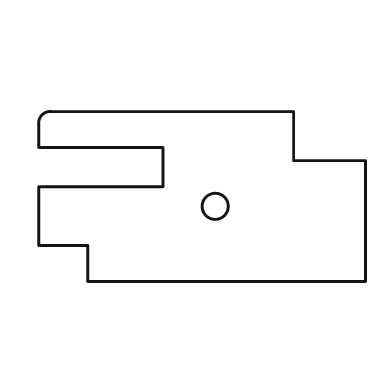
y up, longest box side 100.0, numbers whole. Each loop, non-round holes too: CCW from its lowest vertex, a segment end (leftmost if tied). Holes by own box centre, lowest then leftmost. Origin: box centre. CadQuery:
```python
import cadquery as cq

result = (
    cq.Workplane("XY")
    .moveTo(-35.0, -26.0)
    .lineTo(50.0, -26.0)
    .lineTo(50.0, 11.0)
    .lineTo(28.0, 11.0)
    .lineTo(28.0, 26.0)
    .lineTo(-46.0, 26.0)
    .threePointArc((-49.0, 25.0), (-50.0, 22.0))
    .lineTo(-50.0, 15.0)
    .lineTo(-12.0, 15.0)
    .lineTo(-12.0, 3.0)
    .lineTo(-50.0, 3.0)
    .lineTo(-50.0, -15.0)
    .lineTo(-35.0, -15.0)
    .close()
    .moveTo(4.0, -3.0)
    .circle(4.0)
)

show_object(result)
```